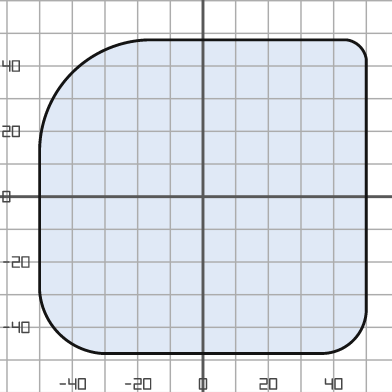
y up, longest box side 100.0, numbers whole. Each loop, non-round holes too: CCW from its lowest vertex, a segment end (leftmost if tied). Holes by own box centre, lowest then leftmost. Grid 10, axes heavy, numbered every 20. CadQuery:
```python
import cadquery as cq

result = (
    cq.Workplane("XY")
    .moveTo(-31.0, -48.0)
    .lineTo(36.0, -48.0)
    .threePointArc((46.0, -44.0), (50.0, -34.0))
    .lineTo(50.0, 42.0)
    .threePointArc((48.0, 46.0), (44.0, 48.0))
    .lineTo(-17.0, 48.0)
    .threePointArc((-40.0, 38.0), (-50.0, 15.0))
    .lineTo(-50.0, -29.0)
    .threePointArc((-44.0, -42.0), (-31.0, -48.0))
    .close()
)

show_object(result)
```